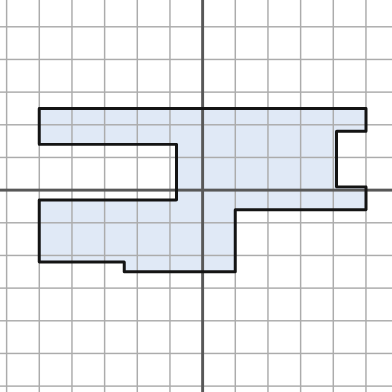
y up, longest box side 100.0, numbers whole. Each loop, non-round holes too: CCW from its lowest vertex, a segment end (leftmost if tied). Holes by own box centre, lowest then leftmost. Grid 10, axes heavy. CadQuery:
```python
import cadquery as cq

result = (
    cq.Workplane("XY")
    .moveTo(-24.0, -25.0)
    .lineTo(10.0, -25.0)
    .lineTo(10.0, -6.0)
    .lineTo(50.0, -6.0)
    .lineTo(50.0, 1.0)
    .lineTo(41.0, 1.0)
    .lineTo(41.0, 18.0)
    .lineTo(50.0, 18.0)
    .lineTo(50.0, 25.0)
    .lineTo(-50.0, 25.0)
    .lineTo(-50.0, 14.0)
    .lineTo(-8.0, 14.0)
    .lineTo(-8.0, -3.0)
    .lineTo(-50.0, -3.0)
    .lineTo(-50.0, -22.0)
    .lineTo(-24.0, -22.0)
    .close()
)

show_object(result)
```